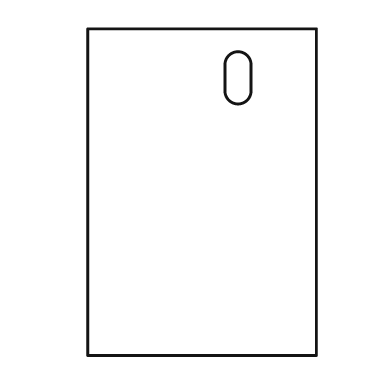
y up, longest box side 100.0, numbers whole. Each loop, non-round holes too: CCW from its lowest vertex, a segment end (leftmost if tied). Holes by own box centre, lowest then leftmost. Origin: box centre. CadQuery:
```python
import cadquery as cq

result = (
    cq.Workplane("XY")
    .moveTo(-35.0, -50.0)
    .lineTo(35.0, -50.0)
    .lineTo(35.0, 50.0)
    .lineTo(-35.0, 50.0)
    .close()
    .moveTo(7.0, 31.0)
    .threePointArc((11.0, 27.0), (15.0, 31.0))
    .lineTo(15.0, 39.0)
    .threePointArc((11.0, 43.0), (7.0, 39.0))
    .close()
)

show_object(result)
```